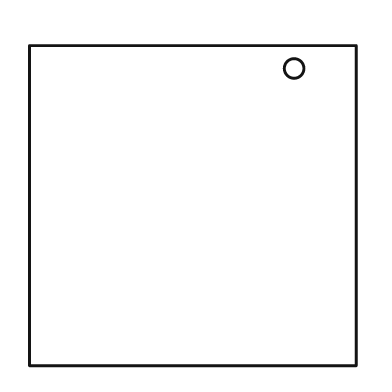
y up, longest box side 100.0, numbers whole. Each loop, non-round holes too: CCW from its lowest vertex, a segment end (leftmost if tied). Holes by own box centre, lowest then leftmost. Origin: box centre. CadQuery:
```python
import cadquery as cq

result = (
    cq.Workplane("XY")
    .moveTo(-50.0, -49.0)
    .lineTo(50.0, -49.0)
    .lineTo(50.0, 49.0)
    .lineTo(-50.0, 49.0)
    .close()
    .moveTo(31.0, 42.0)
    .circle(3.0)
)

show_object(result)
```